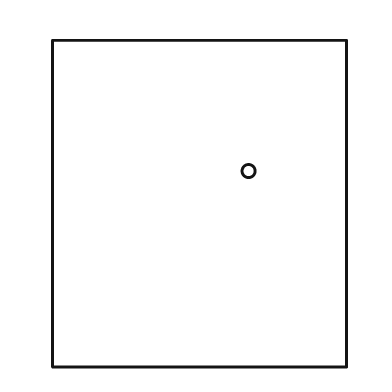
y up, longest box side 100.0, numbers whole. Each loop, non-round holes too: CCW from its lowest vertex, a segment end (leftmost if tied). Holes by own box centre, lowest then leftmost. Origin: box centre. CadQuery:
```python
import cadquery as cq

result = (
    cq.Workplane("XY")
    .moveTo(-45.0, -50.0)
    .lineTo(45.0, -50.0)
    .lineTo(45.0, 50.0)
    .lineTo(-45.0, 50.0)
    .close()
    .moveTo(15.0, 10.0)
    .circle(2.0)
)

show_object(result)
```